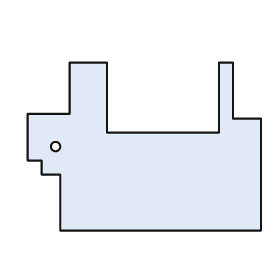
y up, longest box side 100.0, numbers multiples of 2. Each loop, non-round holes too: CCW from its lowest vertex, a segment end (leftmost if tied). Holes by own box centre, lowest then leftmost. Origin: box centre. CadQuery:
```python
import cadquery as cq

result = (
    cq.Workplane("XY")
    .moveTo(-36.0, -36.0)
    .lineTo(50.0, -36.0)
    .lineTo(50.0, 12.0)
    .lineTo(38.0, 12.0)
    .lineTo(38.0, 36.0)
    .lineTo(32.0, 36.0)
    .lineTo(32.0, 6.0)
    .lineTo(-16.0, 6.0)
    .lineTo(-16.0, 36.0)
    .lineTo(-32.0, 36.0)
    .lineTo(-32.0, 14.0)
    .lineTo(-50.0, 14.0)
    .lineTo(-50.0, -6.0)
    .lineTo(-44.0, -6.0)
    .lineTo(-44.0, -12.0)
    .lineTo(-36.0, -12.0)
    .close()
    .moveTo(-38.0, 0.0)
    .circle(2.0)
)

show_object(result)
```